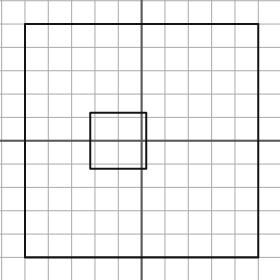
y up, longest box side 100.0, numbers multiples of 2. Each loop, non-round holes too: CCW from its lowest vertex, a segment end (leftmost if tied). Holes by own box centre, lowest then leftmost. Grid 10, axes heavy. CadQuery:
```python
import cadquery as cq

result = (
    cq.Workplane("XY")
    .moveTo(-50.0, -50.0)
    .lineTo(50.0, -50.0)
    .lineTo(50.0, 50.0)
    .lineTo(-50.0, 50.0)
    .close()
    .moveTo(-22.0, -12.0)
    .lineTo(2.0, -12.0)
    .lineTo(2.0, 12.0)
    .lineTo(-22.0, 12.0)
    .close()
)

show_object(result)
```